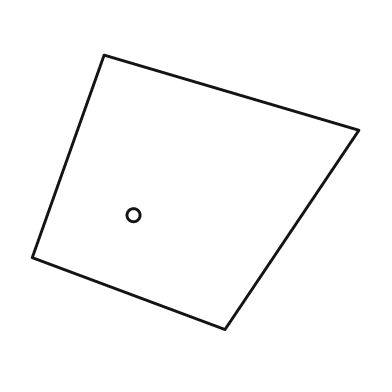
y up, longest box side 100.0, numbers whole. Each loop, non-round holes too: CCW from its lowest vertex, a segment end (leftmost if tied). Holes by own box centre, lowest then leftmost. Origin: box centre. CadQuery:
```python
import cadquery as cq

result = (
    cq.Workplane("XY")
    .moveTo(9.0, -42.0)
    .lineTo(50.0, 19.0)
    .lineTo(-28.0, 42.0)
    .lineTo(-50.0, -20.0)
    .close()
    .moveTo(-19.0, -7.0)
    .circle(2.0)
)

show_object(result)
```